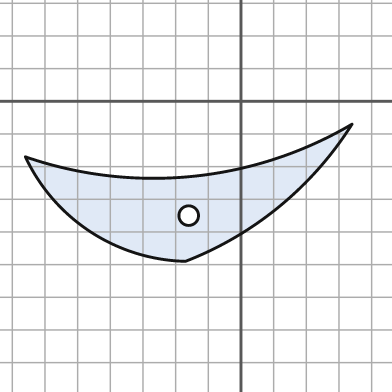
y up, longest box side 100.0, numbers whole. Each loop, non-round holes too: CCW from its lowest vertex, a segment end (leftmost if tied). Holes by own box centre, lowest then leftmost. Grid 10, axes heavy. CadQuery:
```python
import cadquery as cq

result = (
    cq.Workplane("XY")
    .moveTo(-17.0, -49.0)
    .threePointArc((12.0, -32.0), (34.0, -7.0))
    .threePointArc((-15.0, -23.0), (-66.0, -17.0))
    .threePointArc((-46.0, -40.0), (-17.0, -49.0))
    .close()
    .moveTo(-16.0, -35.0)
    .circle(3.0)
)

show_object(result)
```